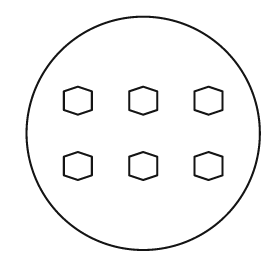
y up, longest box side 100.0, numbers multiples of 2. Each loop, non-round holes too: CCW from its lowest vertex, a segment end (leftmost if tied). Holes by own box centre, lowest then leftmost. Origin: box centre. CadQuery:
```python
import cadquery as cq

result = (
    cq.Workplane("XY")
    .moveTo(0.0, 0.0)
    .circle(50.0)
    .moveTo(-28.0, -20.0)
    .lineTo(-22.0, -18.0)
    .lineTo(-22.0, -10.0)
    .lineTo(-28.0, -8.0)
    .lineTo(-34.0, -10.0)
    .lineTo(-34.0, -18.0)
    .close()
    .moveTo(0.0, -20.0)
    .lineTo(6.0, -18.0)
    .lineTo(6.0, -10.0)
    .lineTo(0.0, -8.0)
    .lineTo(-6.0, -10.0)
    .lineTo(-6.0, -18.0)
    .close()
    .moveTo(28.0, -20.0)
    .lineTo(34.0, -18.0)
    .lineTo(34.0, -10.0)
    .lineTo(28.0, -8.0)
    .lineTo(22.0, -10.0)
    .lineTo(22.0, -18.0)
    .close()
    .moveTo(-28.0, 8.0)
    .lineTo(-22.0, 10.0)
    .lineTo(-22.0, 18.0)
    .lineTo(-28.0, 20.0)
    .lineTo(-34.0, 18.0)
    .lineTo(-34.0, 10.0)
    .close()
    .moveTo(0.0, 8.0)
    .lineTo(6.0, 10.0)
    .lineTo(6.0, 18.0)
    .lineTo(0.0, 20.0)
    .lineTo(-6.0, 18.0)
    .lineTo(-6.0, 10.0)
    .close()
    .moveTo(28.0, 8.0)
    .lineTo(34.0, 10.0)
    .lineTo(34.0, 18.0)
    .lineTo(28.0, 20.0)
    .lineTo(22.0, 18.0)
    .lineTo(22.0, 10.0)
    .close()
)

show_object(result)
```